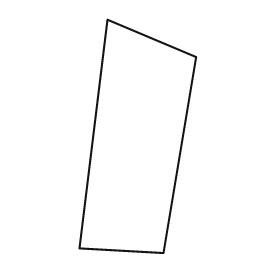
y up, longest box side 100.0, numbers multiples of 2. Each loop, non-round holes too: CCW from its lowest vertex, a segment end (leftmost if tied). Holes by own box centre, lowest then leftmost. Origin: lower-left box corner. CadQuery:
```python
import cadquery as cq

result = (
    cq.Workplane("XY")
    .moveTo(36.0, 0.0)
    .lineTo(50.0, 84.0)
    .lineTo(12.0, 100.0)
    .lineTo(0.0, 2.0)
    .close()
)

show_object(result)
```